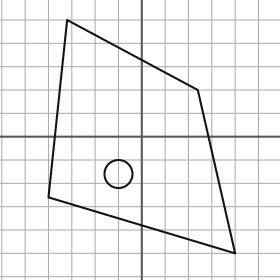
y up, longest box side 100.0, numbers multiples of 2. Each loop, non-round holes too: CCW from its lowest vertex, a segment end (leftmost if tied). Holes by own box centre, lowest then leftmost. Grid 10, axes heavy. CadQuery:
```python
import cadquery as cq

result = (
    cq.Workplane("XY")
    .moveTo(40.0, -50.0)
    .lineTo(24.0, 20.0)
    .lineTo(-32.0, 50.0)
    .lineTo(-40.0, -26.0)
    .close()
    .moveTo(-10.0, -16.0)
    .circle(6.0)
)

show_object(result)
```